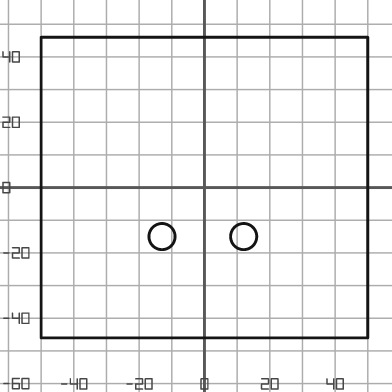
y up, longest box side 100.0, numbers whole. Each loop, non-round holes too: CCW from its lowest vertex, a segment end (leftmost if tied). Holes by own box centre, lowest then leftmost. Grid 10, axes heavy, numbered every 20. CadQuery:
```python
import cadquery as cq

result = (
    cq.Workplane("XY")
    .moveTo(-50.0, -46.0)
    .lineTo(50.0, -46.0)
    .lineTo(50.0, 46.0)
    .lineTo(-50.0, 46.0)
    .close()
    .moveTo(-13.0, -15.0)
    .circle(4.0)
    .moveTo(12.0, -15.0)
    .circle(4.0)
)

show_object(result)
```